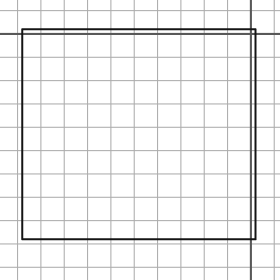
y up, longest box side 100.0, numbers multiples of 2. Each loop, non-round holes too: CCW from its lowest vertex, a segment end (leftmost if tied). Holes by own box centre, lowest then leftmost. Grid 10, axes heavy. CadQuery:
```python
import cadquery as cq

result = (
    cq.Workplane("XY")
    .moveTo(-98.0, -88.0)
    .lineTo(2.0, -88.0)
    .lineTo(2.0, 2.0)
    .lineTo(-98.0, 2.0)
    .close()
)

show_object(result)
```